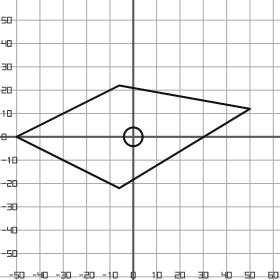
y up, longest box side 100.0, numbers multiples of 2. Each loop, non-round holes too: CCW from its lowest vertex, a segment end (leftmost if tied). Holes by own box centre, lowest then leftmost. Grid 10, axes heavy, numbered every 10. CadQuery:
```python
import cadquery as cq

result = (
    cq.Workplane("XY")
    .moveTo(-6.0, -22.0)
    .lineTo(50.0, 12.0)
    .lineTo(-6.0, 22.0)
    .lineTo(-50.0, 0.0)
    .close()
    .moveTo(0.0, 0.0)
    .circle(4.0)
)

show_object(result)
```